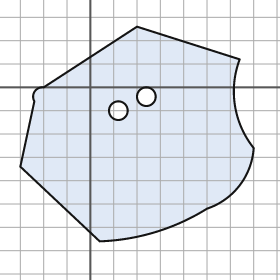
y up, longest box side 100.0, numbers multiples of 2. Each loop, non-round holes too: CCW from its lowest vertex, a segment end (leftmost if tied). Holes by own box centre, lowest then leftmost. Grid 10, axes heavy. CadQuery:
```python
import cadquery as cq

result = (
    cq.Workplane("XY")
    .moveTo(4.0, -66.0)
    .threePointArc((28.0, -62.0), (50.0, -52.0))
    .threePointArc((64.0, -42.0), (70.0, -26.0))
    .threePointArc((62.0, -8.0), (64.0, 12.0))
    .lineTo(20.0, 26.0)
    .lineTo(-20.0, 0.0)
    .threePointArc((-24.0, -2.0), (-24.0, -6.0))
    .lineTo(-30.0, -34.0)
    .close()
    .moveTo(12.0, -10.0)
    .circle(4.0)
    .moveTo(24.0, -4.0)
    .circle(4.0)
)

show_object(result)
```